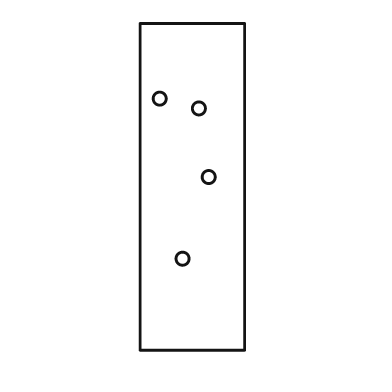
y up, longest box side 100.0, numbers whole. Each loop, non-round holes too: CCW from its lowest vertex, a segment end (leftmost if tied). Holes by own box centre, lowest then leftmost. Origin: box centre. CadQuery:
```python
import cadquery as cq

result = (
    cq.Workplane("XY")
    .moveTo(-16.0, -50.0)
    .lineTo(16.0, -50.0)
    .lineTo(16.0, 50.0)
    .lineTo(-16.0, 50.0)
    .close()
    .moveTo(-3.0, -22.0)
    .circle(2.0)
    .moveTo(5.0, 3.0)
    .circle(2.0)
    .moveTo(2.0, 24.0)
    .circle(2.0)
    .moveTo(-10.0, 27.0)
    .circle(2.0)
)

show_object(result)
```